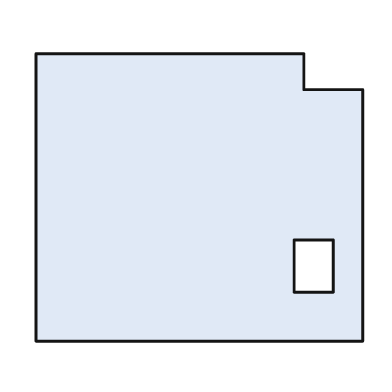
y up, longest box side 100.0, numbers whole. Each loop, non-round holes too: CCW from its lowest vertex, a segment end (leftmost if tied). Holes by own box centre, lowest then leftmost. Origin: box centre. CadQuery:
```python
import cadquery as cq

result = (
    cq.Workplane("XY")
    .moveTo(-50.0, -44.0)
    .lineTo(50.0, -44.0)
    .lineTo(50.0, 33.0)
    .lineTo(32.0, 33.0)
    .lineTo(32.0, 44.0)
    .lineTo(-50.0, 44.0)
    .close()
    .moveTo(29.0, -29.0)
    .lineTo(41.0, -29.0)
    .lineTo(41.0, -13.0)
    .lineTo(29.0, -13.0)
    .close()
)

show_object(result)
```